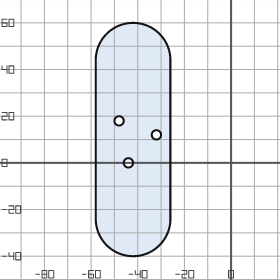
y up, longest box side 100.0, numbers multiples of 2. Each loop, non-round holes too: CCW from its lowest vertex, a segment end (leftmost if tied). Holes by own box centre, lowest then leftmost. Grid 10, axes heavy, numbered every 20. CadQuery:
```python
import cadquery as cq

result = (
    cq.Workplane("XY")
    .moveTo(-58.0, -24.0)
    .threePointArc((-42.0, -40.0), (-26.0, -24.0))
    .lineTo(-26.0, 44.0)
    .threePointArc((-42.0, 60.0), (-58.0, 44.0))
    .close()
    .moveTo(-44.0, 0.0)
    .circle(2.0)
    .moveTo(-32.0, 12.0)
    .circle(2.0)
    .moveTo(-48.0, 18.0)
    .circle(2.0)
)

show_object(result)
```